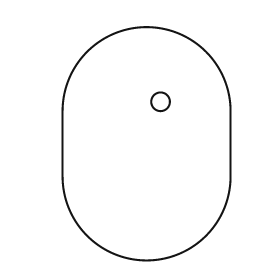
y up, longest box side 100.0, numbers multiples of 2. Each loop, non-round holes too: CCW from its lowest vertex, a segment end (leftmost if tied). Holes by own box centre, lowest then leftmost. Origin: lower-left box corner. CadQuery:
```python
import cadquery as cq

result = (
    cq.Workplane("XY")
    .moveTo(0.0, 36.0)
    .threePointArc((36.0, 0.0), (72.0, 36.0))
    .lineTo(72.0, 64.0)
    .threePointArc((36.0, 100.0), (0.0, 64.0))
    .close()
    .moveTo(42.0, 68.0)
    .circle(4.0)
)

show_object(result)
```